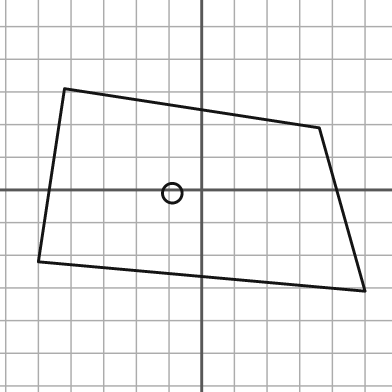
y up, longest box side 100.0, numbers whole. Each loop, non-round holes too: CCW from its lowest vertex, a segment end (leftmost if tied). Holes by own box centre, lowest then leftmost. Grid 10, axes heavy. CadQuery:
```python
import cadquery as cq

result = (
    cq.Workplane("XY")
    .moveTo(50.0, -31.0)
    .lineTo(36.0, 19.0)
    .lineTo(-42.0, 31.0)
    .lineTo(-50.0, -22.0)
    .close()
    .moveTo(-9.0, -1.0)
    .circle(3.0)
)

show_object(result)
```